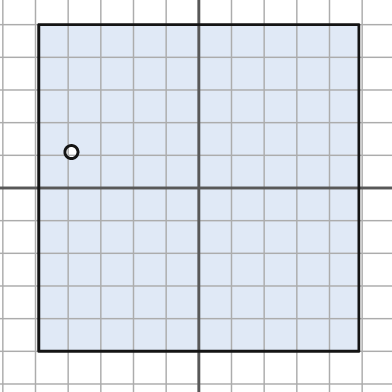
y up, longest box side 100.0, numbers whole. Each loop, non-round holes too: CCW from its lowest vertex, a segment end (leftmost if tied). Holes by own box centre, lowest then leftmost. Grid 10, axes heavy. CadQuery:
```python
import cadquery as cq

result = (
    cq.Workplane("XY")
    .moveTo(-49.0, -50.0)
    .lineTo(49.0, -50.0)
    .lineTo(49.0, 50.0)
    .lineTo(-49.0, 50.0)
    .close()
    .moveTo(-39.0, 11.0)
    .circle(2.0)
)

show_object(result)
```